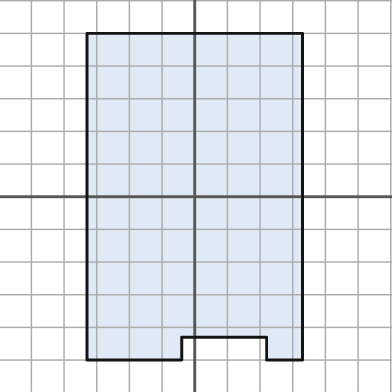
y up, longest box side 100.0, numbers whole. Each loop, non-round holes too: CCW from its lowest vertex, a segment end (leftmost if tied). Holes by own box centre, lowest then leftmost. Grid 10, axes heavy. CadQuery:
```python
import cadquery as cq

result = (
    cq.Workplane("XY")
    .moveTo(-33.0, -50.0)
    .lineTo(-4.0, -50.0)
    .lineTo(-4.0, -43.0)
    .lineTo(22.0, -43.0)
    .lineTo(22.0, -50.0)
    .lineTo(33.0, -50.0)
    .lineTo(33.0, 50.0)
    .lineTo(-33.0, 50.0)
    .close()
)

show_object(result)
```